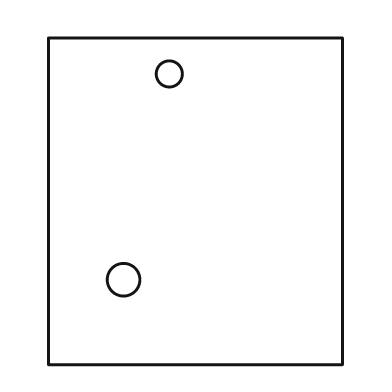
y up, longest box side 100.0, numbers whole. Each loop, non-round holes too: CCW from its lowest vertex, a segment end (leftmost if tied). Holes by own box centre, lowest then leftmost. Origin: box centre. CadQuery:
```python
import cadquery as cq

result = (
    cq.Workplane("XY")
    .moveTo(-45.0, -50.0)
    .lineTo(45.0, -50.0)
    .lineTo(45.0, 50.0)
    .lineTo(-45.0, 50.0)
    .close()
    .moveTo(-22.0, -24.0)
    .circle(5.0)
    .moveTo(-8.0, 39.0)
    .circle(4.0)
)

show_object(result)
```